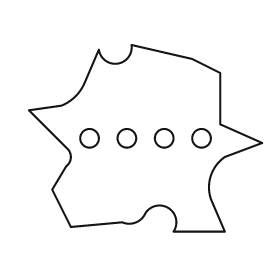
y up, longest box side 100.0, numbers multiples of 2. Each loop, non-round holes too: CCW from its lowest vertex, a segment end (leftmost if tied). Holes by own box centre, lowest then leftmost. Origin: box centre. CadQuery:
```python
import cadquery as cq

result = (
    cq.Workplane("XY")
    .moveTo(12.0, -40.0)
    .lineTo(34.0, -40.0)
    .lineTo(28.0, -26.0)
    .threePointArc((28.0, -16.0), (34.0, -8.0))
    .lineTo(50.0, -2.0)
    .lineTo(32.0, 6.0)
    .lineTo(32.0, 28.0)
    .lineTo(20.0, 34.0)
    .lineTo(-6.0, 40.0)
    .threePointArc((-12.0, 32.0), (-20.0, 38.0))
    .lineTo(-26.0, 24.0)
    .threePointArc((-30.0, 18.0), (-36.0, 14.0))
    .lineTo(-50.0, 12.0)
    .lineTo(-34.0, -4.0)
    .threePointArc((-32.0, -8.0), (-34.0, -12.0))
    .lineTo(-40.0, -22.0)
    .lineTo(-32.0, -38.0)
    .lineTo(-10.0, -36.0)
    .threePointArc((-4.0, -36.0), (0.0, -32.0))
    .threePointArc((10.0, -30.0), (12.0, -40.0))
    .close()
    .moveTo(-24.0, 0.0)
    .circle(4.0)
    .moveTo(-8.0, 0.0)
    .circle(4.0)
    .moveTo(8.0, 0.0)
    .circle(4.0)
    .moveTo(24.0, 0.0)
    .circle(4.0)
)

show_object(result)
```